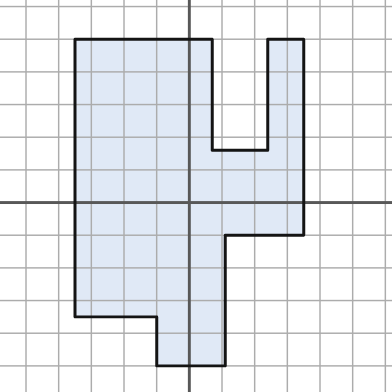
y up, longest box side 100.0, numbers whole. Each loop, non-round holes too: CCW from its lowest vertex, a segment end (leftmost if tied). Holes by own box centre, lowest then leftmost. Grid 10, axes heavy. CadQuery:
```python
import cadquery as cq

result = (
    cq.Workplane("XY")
    .moveTo(-10.0, -50.0)
    .lineTo(11.0, -50.0)
    .lineTo(11.0, -10.0)
    .lineTo(35.0, -10.0)
    .lineTo(35.0, 50.0)
    .lineTo(24.0, 50.0)
    .lineTo(24.0, 16.0)
    .lineTo(7.0, 16.0)
    .lineTo(7.0, 50.0)
    .lineTo(-35.0, 50.0)
    .lineTo(-35.0, -35.0)
    .lineTo(-10.0, -35.0)
    .close()
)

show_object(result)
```